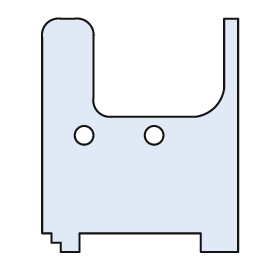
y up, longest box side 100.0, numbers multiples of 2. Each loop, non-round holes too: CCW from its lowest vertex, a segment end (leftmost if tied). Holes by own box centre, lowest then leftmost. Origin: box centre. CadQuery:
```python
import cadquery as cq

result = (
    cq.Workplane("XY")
    .moveTo(-34.0, -50.0)
    .lineTo(-26.0, -50.0)
    .lineTo(-26.0, -42.0)
    .lineTo(26.0, -42.0)
    .lineTo(26.0, -50.0)
    .lineTo(42.0, -50.0)
    .lineTo(42.0, 50.0)
    .lineTo(36.0, 50.0)
    .lineTo(36.0, 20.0)
    .threePointArc((32.0, 12.0), (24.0, 8.0))
    .lineTo(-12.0, 8.0)
    .threePointArc((-18.0, 10.0), (-20.0, 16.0))
    .lineTo(-20.0, 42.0)
    .threePointArc((-22.0, 48.0), (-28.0, 50.0))
    .lineTo(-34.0, 50.0)
    .threePointArc((-40.0, 48.0), (-42.0, 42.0))
    .lineTo(-42.0, -42.0)
    .lineTo(-38.0, -42.0)
    .lineTo(-38.0, -46.0)
    .lineTo(-34.0, -46.0)
    .close()
    .moveTo(-24.0, 0.0)
    .circle(4.0)
    .moveTo(6.0, 0.0)
    .circle(4.0)
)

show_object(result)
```